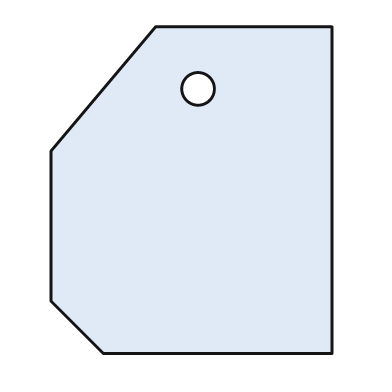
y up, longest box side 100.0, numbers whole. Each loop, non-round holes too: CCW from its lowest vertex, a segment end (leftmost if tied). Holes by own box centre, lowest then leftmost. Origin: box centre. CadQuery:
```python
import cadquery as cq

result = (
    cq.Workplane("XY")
    .moveTo(-27.0, -50.0)
    .lineTo(43.0, -50.0)
    .lineTo(43.0, 50.0)
    .lineTo(-11.0, 50.0)
    .lineTo(-43.0, 12.0)
    .lineTo(-43.0, -34.0)
    .close()
    .moveTo(2.0, 31.0)
    .circle(5.0)
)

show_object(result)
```